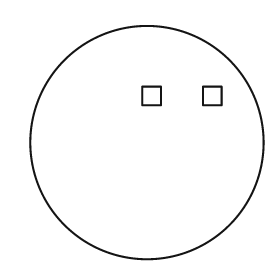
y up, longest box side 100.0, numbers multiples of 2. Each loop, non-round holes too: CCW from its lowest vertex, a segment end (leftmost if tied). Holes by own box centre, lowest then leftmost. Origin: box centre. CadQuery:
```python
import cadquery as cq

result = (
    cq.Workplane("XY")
    .moveTo(0.0, 0.0)
    .circle(50.0)
    .moveTo(-2.0, 16.0)
    .lineTo(6.0, 16.0)
    .lineTo(6.0, 24.0)
    .lineTo(-2.0, 24.0)
    .close()
    .moveTo(24.0, 16.0)
    .lineTo(32.0, 16.0)
    .lineTo(32.0, 24.0)
    .lineTo(24.0, 24.0)
    .close()
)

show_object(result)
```